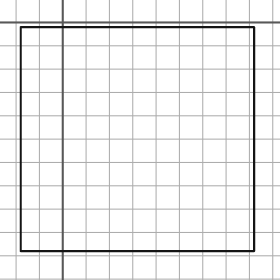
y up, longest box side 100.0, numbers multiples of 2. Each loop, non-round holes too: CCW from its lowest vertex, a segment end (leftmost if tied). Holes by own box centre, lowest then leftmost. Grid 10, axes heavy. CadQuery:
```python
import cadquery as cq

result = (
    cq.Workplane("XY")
    .moveTo(-18.0, -98.0)
    .lineTo(82.0, -98.0)
    .lineTo(82.0, -2.0)
    .lineTo(-18.0, -2.0)
    .close()
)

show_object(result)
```